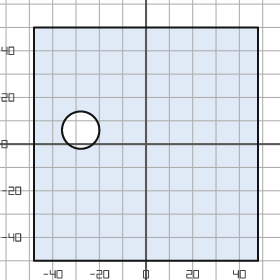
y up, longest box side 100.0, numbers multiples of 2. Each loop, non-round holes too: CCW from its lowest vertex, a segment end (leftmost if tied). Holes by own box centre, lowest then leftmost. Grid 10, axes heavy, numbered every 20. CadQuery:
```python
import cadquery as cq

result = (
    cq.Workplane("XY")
    .moveTo(-48.0, -50.0)
    .lineTo(48.0, -50.0)
    .lineTo(48.0, 50.0)
    .lineTo(-48.0, 50.0)
    .close()
    .moveTo(-28.0, 6.0)
    .circle(8.0)
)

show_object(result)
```